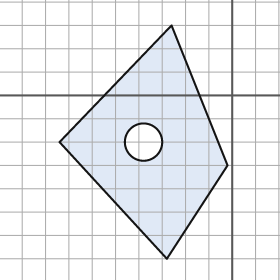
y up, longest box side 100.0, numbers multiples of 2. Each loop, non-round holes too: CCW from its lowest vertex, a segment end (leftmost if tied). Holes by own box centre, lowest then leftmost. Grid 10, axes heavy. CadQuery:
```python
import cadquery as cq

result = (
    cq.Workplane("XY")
    .moveTo(-28.0, -70.0)
    .lineTo(-2.0, -30.0)
    .lineTo(-26.0, 30.0)
    .lineTo(-74.0, -20.0)
    .close()
    .moveTo(-38.0, -20.0)
    .circle(8.0)
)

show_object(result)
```